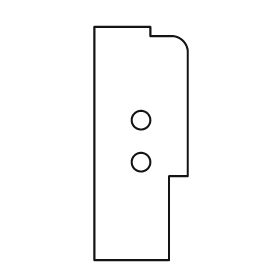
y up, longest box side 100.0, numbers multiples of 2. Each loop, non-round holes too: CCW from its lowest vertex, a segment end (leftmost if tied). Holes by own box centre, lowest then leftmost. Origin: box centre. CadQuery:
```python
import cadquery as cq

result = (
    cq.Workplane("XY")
    .moveTo(-20.0, -50.0)
    .lineTo(12.0, -50.0)
    .lineTo(12.0, -14.0)
    .lineTo(20.0, -14.0)
    .lineTo(20.0, 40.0)
    .threePointArc((18.0, 44.0), (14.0, 46.0))
    .lineTo(4.0, 46.0)
    .lineTo(4.0, 50.0)
    .lineTo(-20.0, 50.0)
    .close()
    .moveTo(0.0, -8.0)
    .circle(4.0)
    .moveTo(0.0, 10.0)
    .circle(4.0)
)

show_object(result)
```